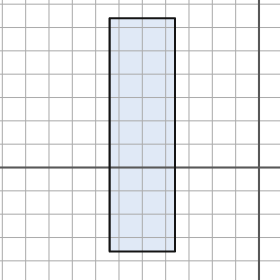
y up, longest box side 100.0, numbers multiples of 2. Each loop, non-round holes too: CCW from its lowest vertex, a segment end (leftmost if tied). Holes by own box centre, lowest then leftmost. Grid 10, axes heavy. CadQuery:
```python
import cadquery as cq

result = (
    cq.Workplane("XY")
    .moveTo(-64.0, -36.0)
    .lineTo(-36.0, -36.0)
    .lineTo(-36.0, 64.0)
    .lineTo(-64.0, 64.0)
    .close()
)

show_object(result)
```